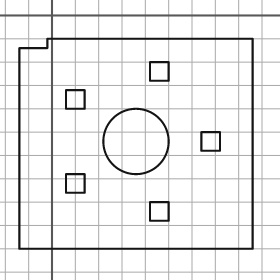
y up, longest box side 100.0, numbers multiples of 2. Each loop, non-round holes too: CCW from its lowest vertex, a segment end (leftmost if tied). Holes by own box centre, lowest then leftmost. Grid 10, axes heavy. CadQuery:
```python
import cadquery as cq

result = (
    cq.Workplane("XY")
    .moveTo(-14.0, -100.0)
    .lineTo(86.0, -100.0)
    .lineTo(86.0, -10.0)
    .lineTo(-2.0, -10.0)
    .lineTo(-2.0, -14.0)
    .lineTo(-14.0, -14.0)
    .close()
    .moveTo(42.0, -88.0)
    .lineTo(50.0, -88.0)
    .lineTo(50.0, -80.0)
    .lineTo(42.0, -80.0)
    .close()
    .moveTo(6.0, -76.0)
    .lineTo(14.0, -76.0)
    .lineTo(14.0, -68.0)
    .lineTo(6.0, -68.0)
    .close()
    .moveTo(36.0, -54.0)
    .circle(14.0)
    .moveTo(64.0, -58.0)
    .lineTo(72.0, -58.0)
    .lineTo(72.0, -50.0)
    .lineTo(64.0, -50.0)
    .close()
    .moveTo(6.0, -40.0)
    .lineTo(14.0, -40.0)
    .lineTo(14.0, -32.0)
    .lineTo(6.0, -32.0)
    .close()
    .moveTo(42.0, -28.0)
    .lineTo(50.0, -28.0)
    .lineTo(50.0, -20.0)
    .lineTo(42.0, -20.0)
    .close()
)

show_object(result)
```